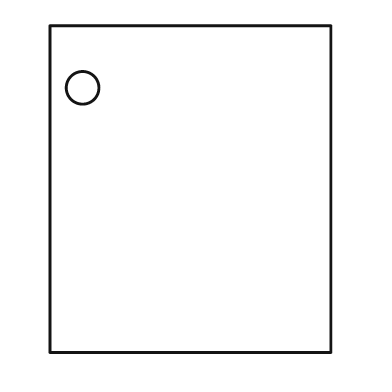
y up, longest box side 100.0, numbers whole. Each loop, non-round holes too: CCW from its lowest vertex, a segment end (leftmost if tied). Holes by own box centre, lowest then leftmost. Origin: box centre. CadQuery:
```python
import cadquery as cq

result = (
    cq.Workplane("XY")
    .moveTo(-43.0, -50.0)
    .lineTo(43.0, -50.0)
    .lineTo(43.0, 50.0)
    .lineTo(-43.0, 50.0)
    .close()
    .moveTo(-33.0, 31.0)
    .circle(5.0)
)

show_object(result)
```